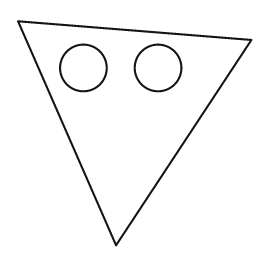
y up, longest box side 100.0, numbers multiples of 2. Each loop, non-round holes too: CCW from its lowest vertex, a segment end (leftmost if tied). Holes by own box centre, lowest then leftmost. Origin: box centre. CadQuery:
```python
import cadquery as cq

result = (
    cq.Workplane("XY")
    .moveTo(-8.0, -48.0)
    .lineTo(50.0, 40.0)
    .lineTo(-50.0, 48.0)
    .close()
    .moveTo(-22.0, 28.0)
    .circle(10.0)
    .moveTo(10.0, 28.0)
    .circle(10.0)
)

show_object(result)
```